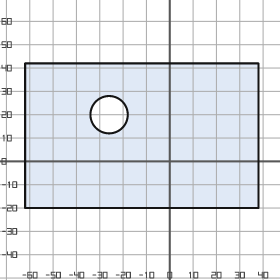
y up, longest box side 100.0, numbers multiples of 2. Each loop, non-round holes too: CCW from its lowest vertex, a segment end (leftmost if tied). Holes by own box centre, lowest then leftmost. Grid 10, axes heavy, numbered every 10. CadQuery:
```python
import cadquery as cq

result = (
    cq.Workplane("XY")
    .moveTo(-62.0, -20.0)
    .lineTo(38.0, -20.0)
    .lineTo(38.0, 42.0)
    .lineTo(-62.0, 42.0)
    .close()
    .moveTo(-26.0, 20.0)
    .circle(8.0)
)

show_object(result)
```